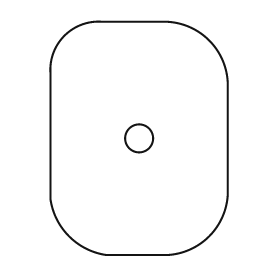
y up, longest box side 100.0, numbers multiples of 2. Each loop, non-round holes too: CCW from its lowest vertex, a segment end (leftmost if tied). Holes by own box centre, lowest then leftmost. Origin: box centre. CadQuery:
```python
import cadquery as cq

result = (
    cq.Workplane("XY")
    .moveTo(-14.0, -50.0)
    .lineTo(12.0, -50.0)
    .threePointArc((30.0, -42.0), (38.0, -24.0))
    .lineTo(38.0, 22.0)
    .threePointArc((30.0, 42.0), (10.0, 50.0))
    .lineTo(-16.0, 50.0)
    .threePointArc((-32.0, 44.0), (-38.0, 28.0))
    .lineTo(-38.0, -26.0)
    .threePointArc((-30.0, -42.0), (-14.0, -50.0))
    .close()
    .moveTo(0.0, 0.0)
    .circle(6.0)
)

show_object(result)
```